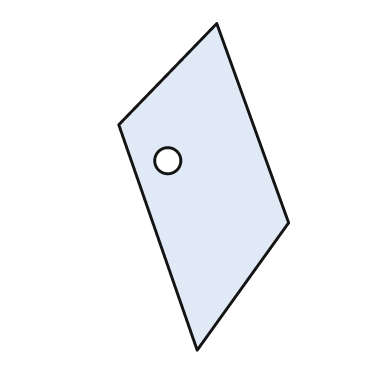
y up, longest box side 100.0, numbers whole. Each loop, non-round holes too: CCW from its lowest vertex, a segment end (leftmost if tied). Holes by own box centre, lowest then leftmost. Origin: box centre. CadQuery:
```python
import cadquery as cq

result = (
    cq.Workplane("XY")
    .moveTo(-2.0, -50.0)
    .lineTo(26.0, -11.0)
    .lineTo(4.0, 50.0)
    .lineTo(-26.0, 19.0)
    .close()
    .moveTo(-11.0, 8.0)
    .circle(4.0)
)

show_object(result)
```